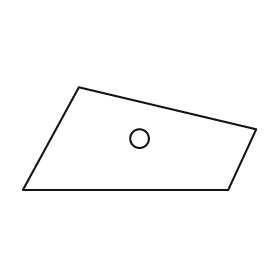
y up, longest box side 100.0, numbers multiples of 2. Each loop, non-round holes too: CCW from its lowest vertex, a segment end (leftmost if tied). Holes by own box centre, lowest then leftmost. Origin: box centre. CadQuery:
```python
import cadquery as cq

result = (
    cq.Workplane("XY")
    .moveTo(-50.0, -22.0)
    .lineTo(38.0, -22.0)
    .lineTo(50.0, 4.0)
    .lineTo(-26.0, 22.0)
    .close()
    .moveTo(0.0, 0.0)
    .circle(4.0)
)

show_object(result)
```